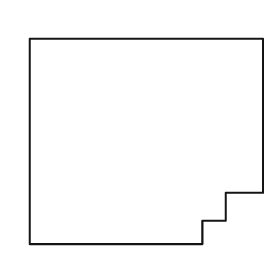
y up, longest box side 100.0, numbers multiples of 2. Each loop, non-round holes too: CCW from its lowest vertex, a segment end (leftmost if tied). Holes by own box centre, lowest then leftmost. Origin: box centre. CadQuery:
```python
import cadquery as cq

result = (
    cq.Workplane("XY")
    .moveTo(-50.0, -44.0)
    .lineTo(24.0, -44.0)
    .lineTo(24.0, -34.0)
    .lineTo(34.0, -34.0)
    .lineTo(34.0, -22.0)
    .lineTo(50.0, -22.0)
    .lineTo(50.0, 44.0)
    .lineTo(-50.0, 44.0)
    .close()
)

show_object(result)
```